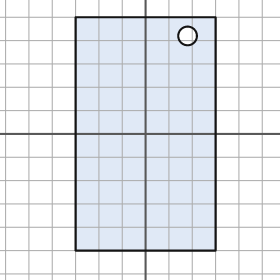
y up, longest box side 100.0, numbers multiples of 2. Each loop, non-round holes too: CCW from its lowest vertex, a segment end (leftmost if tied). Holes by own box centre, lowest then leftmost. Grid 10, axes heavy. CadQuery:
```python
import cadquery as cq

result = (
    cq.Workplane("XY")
    .moveTo(-30.0, -50.0)
    .lineTo(30.0, -50.0)
    .lineTo(30.0, 50.0)
    .lineTo(-30.0, 50.0)
    .close()
    .moveTo(18.0, 42.0)
    .circle(4.0)
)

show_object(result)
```